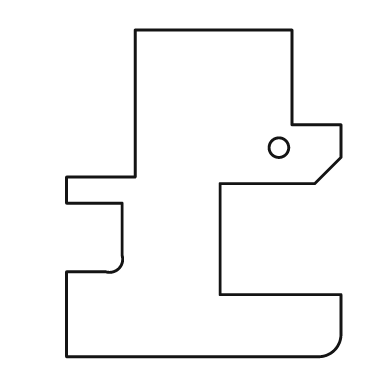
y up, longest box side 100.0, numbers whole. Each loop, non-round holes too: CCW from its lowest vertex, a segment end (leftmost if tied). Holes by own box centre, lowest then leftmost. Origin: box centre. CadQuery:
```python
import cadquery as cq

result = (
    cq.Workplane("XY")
    .moveTo(-42.0, -50.0)
    .lineTo(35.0, -50.0)
    .threePointArc((40.0, -48.0), (42.0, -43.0))
    .lineTo(42.0, -31.0)
    .lineTo(5.0, -31.0)
    .lineTo(5.0, 3.0)
    .lineTo(34.0, 3.0)
    .lineTo(42.0, 11.0)
    .lineTo(42.0, 21.0)
    .lineTo(27.0, 21.0)
    .lineTo(27.0, 50.0)
    .lineTo(-21.0, 50.0)
    .lineTo(-21.0, 5.0)
    .lineTo(-42.0, 5.0)
    .lineTo(-42.0, -3.0)
    .lineTo(-25.0, -3.0)
    .lineTo(-25.0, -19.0)
    .threePointArc((-26.0, -23.0), (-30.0, -24.0))
    .lineTo(-42.0, -24.0)
    .close()
    .moveTo(23.0, 14.0)
    .circle(3.0)
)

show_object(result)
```